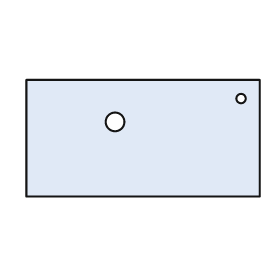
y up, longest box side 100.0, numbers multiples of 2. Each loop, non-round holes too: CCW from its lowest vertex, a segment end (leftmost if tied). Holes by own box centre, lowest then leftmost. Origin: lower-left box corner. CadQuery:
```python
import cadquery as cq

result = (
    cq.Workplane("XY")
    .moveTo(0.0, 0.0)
    .lineTo(100.0, 0.0)
    .lineTo(100.0, 50.0)
    .lineTo(0.0, 50.0)
    .close()
    .moveTo(38.0, 32.0)
    .circle(4.0)
    .moveTo(92.0, 42.0)
    .circle(2.0)
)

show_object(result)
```